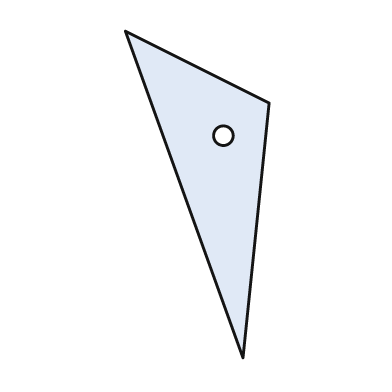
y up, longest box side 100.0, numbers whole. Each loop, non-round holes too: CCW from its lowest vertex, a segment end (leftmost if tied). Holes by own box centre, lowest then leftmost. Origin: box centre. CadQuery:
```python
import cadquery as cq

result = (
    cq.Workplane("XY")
    .moveTo(14.0, -50.0)
    .lineTo(22.0, 28.0)
    .lineTo(-22.0, 50.0)
    .close()
    .moveTo(8.0, 18.0)
    .circle(3.0)
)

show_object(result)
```